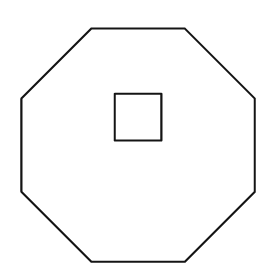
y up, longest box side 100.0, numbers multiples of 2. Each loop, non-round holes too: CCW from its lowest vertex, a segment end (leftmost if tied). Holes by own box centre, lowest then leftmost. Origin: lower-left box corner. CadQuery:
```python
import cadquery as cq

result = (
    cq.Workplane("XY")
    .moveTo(30.0, 0.0)
    .lineTo(70.0, 0.0)
    .lineTo(100.0, 30.0)
    .lineTo(100.0, 70.0)
    .lineTo(70.0, 100.0)
    .lineTo(30.0, 100.0)
    .lineTo(0.0, 70.0)
    .lineTo(0.0, 30.0)
    .close()
    .moveTo(40.0, 52.0)
    .lineTo(60.0, 52.0)
    .lineTo(60.0, 72.0)
    .lineTo(40.0, 72.0)
    .close()
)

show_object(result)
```